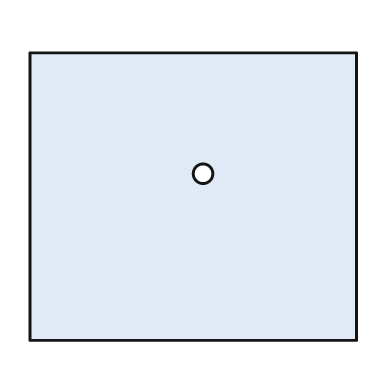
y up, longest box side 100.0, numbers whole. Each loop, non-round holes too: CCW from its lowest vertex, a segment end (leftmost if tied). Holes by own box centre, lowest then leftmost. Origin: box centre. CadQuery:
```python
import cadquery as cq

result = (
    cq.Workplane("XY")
    .moveTo(-50.0, -44.0)
    .lineTo(50.0, -44.0)
    .lineTo(50.0, 44.0)
    .lineTo(-50.0, 44.0)
    .close()
    .moveTo(3.0, 7.0)
    .circle(3.0)
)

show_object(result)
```